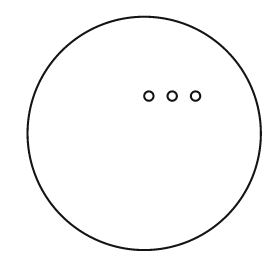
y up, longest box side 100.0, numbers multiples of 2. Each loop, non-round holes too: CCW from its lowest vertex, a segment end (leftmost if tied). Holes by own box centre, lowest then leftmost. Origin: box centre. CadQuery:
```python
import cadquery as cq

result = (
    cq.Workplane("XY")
    .moveTo(0.0, 0.0)
    .circle(50.0)
    .moveTo(2.0, 16.0)
    .circle(2.0)
    .moveTo(12.0, 16.0)
    .circle(2.0)
    .moveTo(22.0, 16.0)
    .circle(2.0)
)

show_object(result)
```